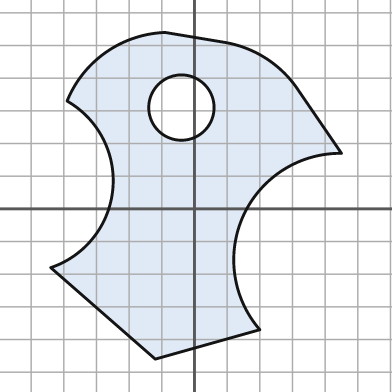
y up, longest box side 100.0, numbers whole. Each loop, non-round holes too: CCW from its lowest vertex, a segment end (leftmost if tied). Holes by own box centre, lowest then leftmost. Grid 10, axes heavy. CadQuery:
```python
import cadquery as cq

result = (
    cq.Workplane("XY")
    .moveTo(-12.0, -46.0)
    .lineTo(20.0, -37.0)
    .threePointArc((15.0, -2.0), (45.0, 17.0))
    .lineTo(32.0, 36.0)
    .threePointArc((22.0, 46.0), (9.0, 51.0))
    .lineTo(-9.0, 54.0)
    .threePointArc((-27.0, 48.0), (-39.0, 33.0))
    .threePointArc((-25.0, 6.0), (-44.0, -18.0))
    .close()
    .moveTo(-4.0, 31.0)
    .circle(10.0)
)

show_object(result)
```